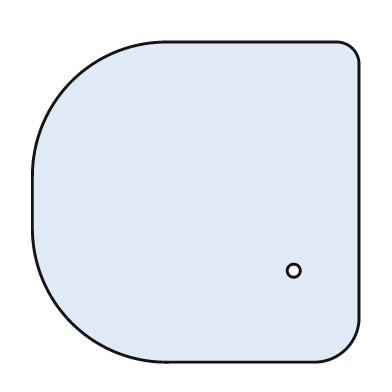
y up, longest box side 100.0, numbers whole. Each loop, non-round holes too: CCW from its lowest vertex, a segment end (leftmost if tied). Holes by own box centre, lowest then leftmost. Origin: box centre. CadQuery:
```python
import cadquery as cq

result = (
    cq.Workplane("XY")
    .moveTo(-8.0, -49.0)
    .lineTo(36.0, -49.0)
    .threePointArc((46.0, -45.0), (50.0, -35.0))
    .lineTo(50.0, 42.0)
    .threePointArc((48.0, 47.0), (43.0, 49.0))
    .lineTo(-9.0, 49.0)
    .threePointArc((-38.0, 37.0), (-50.0, 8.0))
    .lineTo(-50.0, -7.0)
    .threePointArc((-38.0, -37.0), (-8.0, -49.0))
    .close()
    .moveTo(30.0, -21.0)
    .circle(2.0)
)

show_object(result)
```